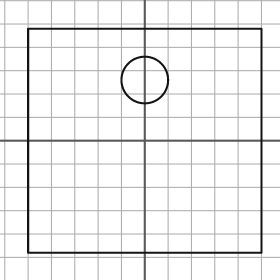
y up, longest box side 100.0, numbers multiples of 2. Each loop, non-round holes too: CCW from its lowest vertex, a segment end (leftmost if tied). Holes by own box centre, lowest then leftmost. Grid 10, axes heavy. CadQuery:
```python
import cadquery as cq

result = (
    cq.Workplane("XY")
    .moveTo(-50.0, -48.0)
    .lineTo(50.0, -48.0)
    .lineTo(50.0, 48.0)
    .lineTo(-50.0, 48.0)
    .close()
    .moveTo(0.0, 26.0)
    .circle(10.0)
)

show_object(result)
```